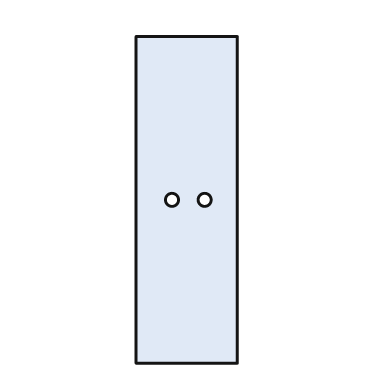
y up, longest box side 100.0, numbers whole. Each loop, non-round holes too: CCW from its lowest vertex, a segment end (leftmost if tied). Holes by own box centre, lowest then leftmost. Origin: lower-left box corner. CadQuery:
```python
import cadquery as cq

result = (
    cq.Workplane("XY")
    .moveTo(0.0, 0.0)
    .lineTo(31.0, 0.0)
    .lineTo(31.0, 100.0)
    .lineTo(0.0, 100.0)
    .close()
    .moveTo(11.0, 50.0)
    .circle(2.0)
    .moveTo(21.0, 50.0)
    .circle(2.0)
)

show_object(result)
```